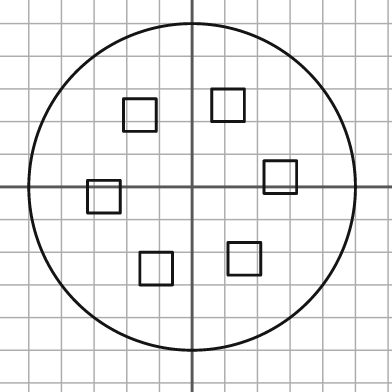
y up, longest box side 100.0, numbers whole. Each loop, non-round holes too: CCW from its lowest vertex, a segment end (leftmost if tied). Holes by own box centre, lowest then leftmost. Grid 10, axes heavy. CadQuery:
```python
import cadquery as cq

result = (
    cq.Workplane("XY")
    .moveTo(0.0, 0.0)
    .circle(50.0)
    .moveTo(-16.0, -30.0)
    .lineTo(-6.0, -30.0)
    .lineTo(-6.0, -20.0)
    .lineTo(-16.0, -20.0)
    .close()
    .moveTo(11.0, -27.0)
    .lineTo(21.0, -27.0)
    .lineTo(21.0, -17.0)
    .lineTo(11.0, -17.0)
    .close()
    .moveTo(-32.0, -8.0)
    .lineTo(-22.0, -8.0)
    .lineTo(-22.0, 2.0)
    .lineTo(-32.0, 2.0)
    .close()
    .moveTo(22.0, -2.0)
    .lineTo(32.0, -2.0)
    .lineTo(32.0, 8.0)
    .lineTo(22.0, 8.0)
    .close()
    .moveTo(-21.0, 17.0)
    .lineTo(-11.0, 17.0)
    .lineTo(-11.0, 27.0)
    .lineTo(-21.0, 27.0)
    .close()
    .moveTo(6.0, 20.0)
    .lineTo(16.0, 20.0)
    .lineTo(16.0, 30.0)
    .lineTo(6.0, 30.0)
    .close()
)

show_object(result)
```